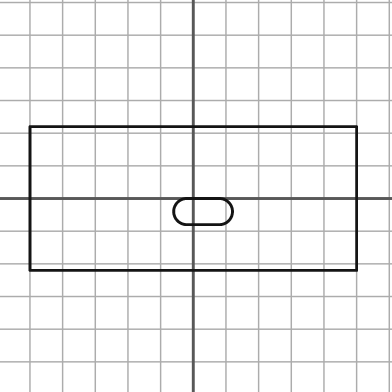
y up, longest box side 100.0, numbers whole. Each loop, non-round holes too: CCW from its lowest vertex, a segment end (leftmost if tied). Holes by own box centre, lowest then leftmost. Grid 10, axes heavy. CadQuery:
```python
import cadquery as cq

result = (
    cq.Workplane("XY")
    .moveTo(-50.0, -22.0)
    .lineTo(50.0, -22.0)
    .lineTo(50.0, 22.0)
    .lineTo(-50.0, 22.0)
    .close()
    .moveTo(-2.0, -8.0)
    .lineTo(8.0, -8.0)
    .threePointArc((12.0, -4.0), (8.0, 0.0))
    .lineTo(-2.0, 0.0)
    .threePointArc((-6.0, -4.0), (-2.0, -8.0))
    .close()
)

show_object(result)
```